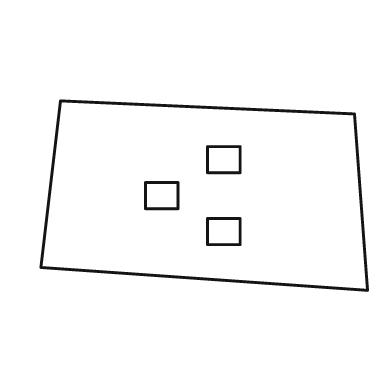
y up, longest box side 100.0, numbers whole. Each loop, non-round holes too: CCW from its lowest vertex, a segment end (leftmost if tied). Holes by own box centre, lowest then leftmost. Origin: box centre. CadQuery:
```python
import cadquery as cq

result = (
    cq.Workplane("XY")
    .moveTo(50.0, -29.0)
    .lineTo(46.0, 25.0)
    .lineTo(-44.0, 29.0)
    .lineTo(-50.0, -22.0)
    .close()
    .moveTo(1.0, -15.0)
    .lineTo(11.0, -15.0)
    .lineTo(11.0, -7.0)
    .lineTo(1.0, -7.0)
    .close()
    .moveTo(-18.0, -4.0)
    .lineTo(-8.0, -4.0)
    .lineTo(-8.0, 4.0)
    .lineTo(-18.0, 4.0)
    .close()
    .moveTo(1.0, 7.0)
    .lineTo(11.0, 7.0)
    .lineTo(11.0, 15.0)
    .lineTo(1.0, 15.0)
    .close()
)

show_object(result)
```